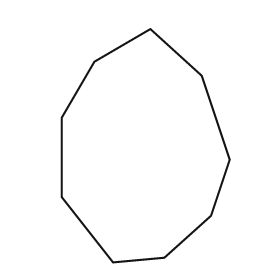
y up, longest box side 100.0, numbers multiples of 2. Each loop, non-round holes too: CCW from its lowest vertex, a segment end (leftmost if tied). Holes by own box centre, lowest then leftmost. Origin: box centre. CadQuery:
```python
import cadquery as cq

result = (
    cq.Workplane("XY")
    .moveTo(-14.0, -50.0)
    .lineTo(8.0, -48.0)
    .lineTo(28.0, -30.0)
    .lineTo(36.0, -6.0)
    .lineTo(24.0, 30.0)
    .lineTo(2.0, 50.0)
    .lineTo(-22.0, 36.0)
    .lineTo(-36.0, 12.0)
    .lineTo(-36.0, -22.0)
    .close()
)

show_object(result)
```